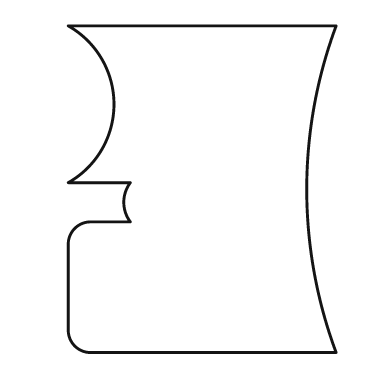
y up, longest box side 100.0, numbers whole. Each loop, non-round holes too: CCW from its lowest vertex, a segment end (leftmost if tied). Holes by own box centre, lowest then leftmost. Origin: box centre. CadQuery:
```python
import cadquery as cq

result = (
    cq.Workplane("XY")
    .moveTo(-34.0, -50.0)
    .lineTo(41.0, -50.0)
    .threePointArc((32.0, 0.0), (41.0, 50.0))
    .lineTo(-41.0, 50.0)
    .threePointArc((-27.0, 26.0), (-41.0, 2.0))
    .lineTo(-22.0, 2.0)
    .threePointArc((-24.0, -4.0), (-22.0, -10.0))
    .lineTo(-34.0, -10.0)
    .threePointArc((-39.0, -12.0), (-41.0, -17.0))
    .lineTo(-41.0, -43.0)
    .threePointArc((-39.0, -48.0), (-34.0, -50.0))
    .close()
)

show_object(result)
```